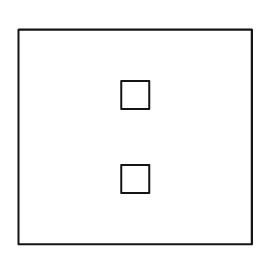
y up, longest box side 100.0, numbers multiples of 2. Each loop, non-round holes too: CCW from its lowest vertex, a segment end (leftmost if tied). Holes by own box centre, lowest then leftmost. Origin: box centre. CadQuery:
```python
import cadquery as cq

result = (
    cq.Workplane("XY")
    .moveTo(-50.0, -46.0)
    .lineTo(50.0, -46.0)
    .lineTo(50.0, 46.0)
    .lineTo(-50.0, 46.0)
    .close()
    .moveTo(-6.0, -24.0)
    .lineTo(6.0, -24.0)
    .lineTo(6.0, -12.0)
    .lineTo(-6.0, -12.0)
    .close()
    .moveTo(-6.0, 12.0)
    .lineTo(6.0, 12.0)
    .lineTo(6.0, 24.0)
    .lineTo(-6.0, 24.0)
    .close()
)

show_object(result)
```